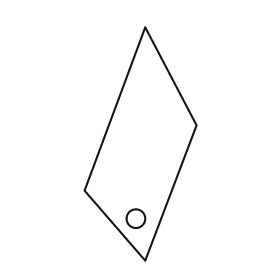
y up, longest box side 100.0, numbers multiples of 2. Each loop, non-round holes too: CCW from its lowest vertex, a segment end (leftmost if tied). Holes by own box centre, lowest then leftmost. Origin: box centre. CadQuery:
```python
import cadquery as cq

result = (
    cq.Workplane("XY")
    .moveTo(2.0, -50.0)
    .lineTo(24.0, 8.0)
    .lineTo(2.0, 50.0)
    .lineTo(-24.0, -20.0)
    .close()
    .moveTo(-2.0, -32.0)
    .circle(4.0)
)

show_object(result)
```